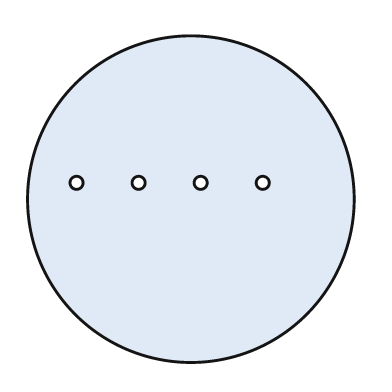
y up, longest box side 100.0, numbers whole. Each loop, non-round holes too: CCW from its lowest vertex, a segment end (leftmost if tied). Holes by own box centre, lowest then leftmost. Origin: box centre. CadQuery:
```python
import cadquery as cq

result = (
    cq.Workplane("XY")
    .moveTo(0.0, 0.0)
    .circle(50.0)
    .moveTo(-35.0, 5.0)
    .circle(2.0)
    .moveTo(-16.0, 5.0)
    .circle(2.0)
    .moveTo(3.0, 5.0)
    .circle(2.0)
    .moveTo(22.0, 5.0)
    .circle(2.0)
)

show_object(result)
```